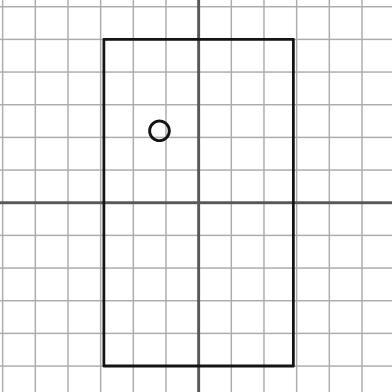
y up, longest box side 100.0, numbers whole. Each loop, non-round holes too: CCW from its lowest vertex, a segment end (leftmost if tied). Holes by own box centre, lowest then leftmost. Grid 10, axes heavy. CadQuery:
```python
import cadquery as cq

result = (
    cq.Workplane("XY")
    .moveTo(-29.0, -50.0)
    .lineTo(29.0, -50.0)
    .lineTo(29.0, 50.0)
    .lineTo(-29.0, 50.0)
    .close()
    .moveTo(-12.0, 22.0)
    .circle(3.0)
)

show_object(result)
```